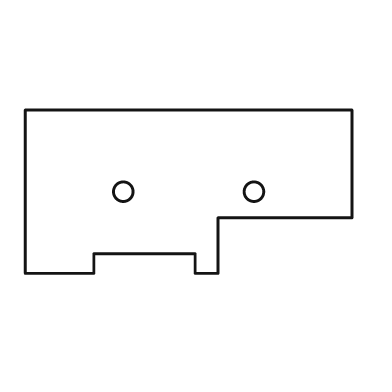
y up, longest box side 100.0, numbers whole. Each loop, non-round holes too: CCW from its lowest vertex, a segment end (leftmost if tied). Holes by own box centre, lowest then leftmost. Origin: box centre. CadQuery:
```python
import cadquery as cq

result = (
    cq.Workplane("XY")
    .moveTo(-50.0, -25.0)
    .lineTo(-29.0, -25.0)
    .lineTo(-29.0, -19.0)
    .lineTo(2.0, -19.0)
    .lineTo(2.0, -25.0)
    .lineTo(9.0, -25.0)
    .lineTo(9.0, -8.0)
    .lineTo(50.0, -8.0)
    .lineTo(50.0, 25.0)
    .lineTo(-50.0, 25.0)
    .close()
    .moveTo(-20.0, 0.0)
    .circle(3.0)
    .moveTo(20.0, 0.0)
    .circle(3.0)
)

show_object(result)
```